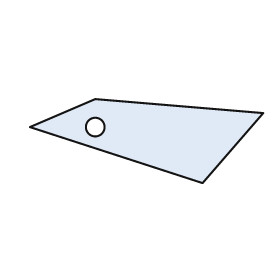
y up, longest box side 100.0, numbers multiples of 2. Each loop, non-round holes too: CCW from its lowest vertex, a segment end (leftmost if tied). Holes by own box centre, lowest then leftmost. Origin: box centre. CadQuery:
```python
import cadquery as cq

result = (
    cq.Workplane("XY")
    .moveTo(24.0, -18.0)
    .lineTo(50.0, 12.0)
    .lineTo(-22.0, 18.0)
    .lineTo(-50.0, 6.0)
    .close()
    .moveTo(-22.0, 6.0)
    .circle(4.0)
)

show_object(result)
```